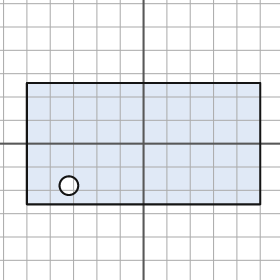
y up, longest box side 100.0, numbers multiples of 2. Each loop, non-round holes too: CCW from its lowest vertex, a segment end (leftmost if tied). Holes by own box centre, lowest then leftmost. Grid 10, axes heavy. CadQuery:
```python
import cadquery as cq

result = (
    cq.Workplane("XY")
    .moveTo(-50.0, -26.0)
    .lineTo(50.0, -26.0)
    .lineTo(50.0, 26.0)
    .lineTo(-50.0, 26.0)
    .close()
    .moveTo(-32.0, -18.0)
    .circle(4.0)
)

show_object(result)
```